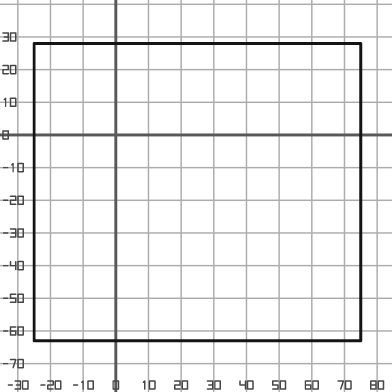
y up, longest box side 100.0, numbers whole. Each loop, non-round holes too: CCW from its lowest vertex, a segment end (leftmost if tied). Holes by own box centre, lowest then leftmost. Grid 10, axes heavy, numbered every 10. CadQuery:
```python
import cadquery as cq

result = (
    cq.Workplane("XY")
    .moveTo(-25.0, -63.0)
    .lineTo(75.0, -63.0)
    .lineTo(75.0, 28.0)
    .lineTo(-25.0, 28.0)
    .close()
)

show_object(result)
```